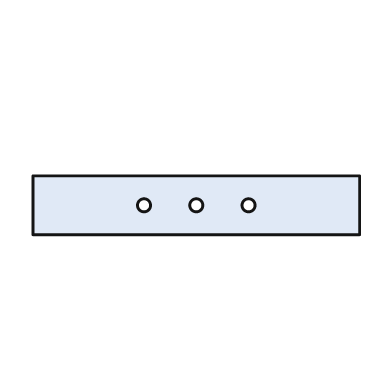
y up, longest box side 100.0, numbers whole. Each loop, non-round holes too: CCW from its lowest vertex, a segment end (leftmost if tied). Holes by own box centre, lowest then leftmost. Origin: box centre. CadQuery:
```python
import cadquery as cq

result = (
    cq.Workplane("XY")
    .moveTo(-50.0, -9.0)
    .lineTo(50.0, -9.0)
    .lineTo(50.0, 9.0)
    .lineTo(-50.0, 9.0)
    .close()
    .moveTo(-16.0, 0.0)
    .circle(2.0)
    .moveTo(0.0, 0.0)
    .circle(2.0)
    .moveTo(16.0, 0.0)
    .circle(2.0)
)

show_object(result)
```